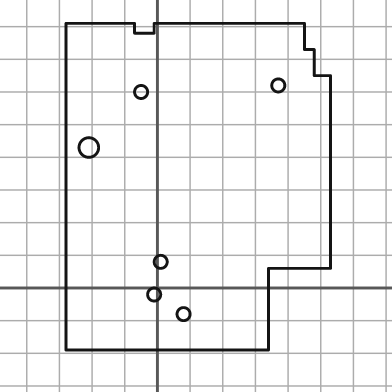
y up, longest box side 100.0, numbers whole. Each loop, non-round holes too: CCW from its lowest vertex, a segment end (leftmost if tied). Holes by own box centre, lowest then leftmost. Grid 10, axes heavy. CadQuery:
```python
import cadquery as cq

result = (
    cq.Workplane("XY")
    .moveTo(-28.0, -19.0)
    .lineTo(34.0, -19.0)
    .lineTo(34.0, 6.0)
    .lineTo(53.0, 6.0)
    .lineTo(53.0, 65.0)
    .lineTo(48.0, 65.0)
    .lineTo(48.0, 73.0)
    .lineTo(45.0, 73.0)
    .lineTo(45.0, 81.0)
    .lineTo(-1.0, 81.0)
    .lineTo(-1.0, 78.0)
    .lineTo(-7.0, 78.0)
    .lineTo(-7.0, 81.0)
    .lineTo(-28.0, 81.0)
    .close()
    .moveTo(8.0, -8.0)
    .circle(2.0)
    .moveTo(-1.0, -2.0)
    .circle(2.0)
    .moveTo(1.0, 8.0)
    .circle(2.0)
    .moveTo(-21.0, 43.0)
    .circle(3.0)
    .moveTo(-5.0, 60.0)
    .circle(2.0)
    .moveTo(37.0, 62.0)
    .circle(2.0)
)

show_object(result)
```